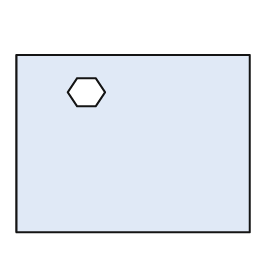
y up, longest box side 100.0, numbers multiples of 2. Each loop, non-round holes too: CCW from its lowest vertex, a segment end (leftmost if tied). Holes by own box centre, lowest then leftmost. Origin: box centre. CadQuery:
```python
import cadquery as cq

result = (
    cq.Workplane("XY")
    .moveTo(-50.0, -38.0)
    .lineTo(50.0, -38.0)
    .lineTo(50.0, 38.0)
    .lineTo(-50.0, 38.0)
    .close()
    .moveTo(-24.0, 16.0)
    .lineTo(-16.0, 16.0)
    .lineTo(-12.0, 22.0)
    .lineTo(-16.0, 28.0)
    .lineTo(-24.0, 28.0)
    .lineTo(-28.0, 22.0)
    .close()
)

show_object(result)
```